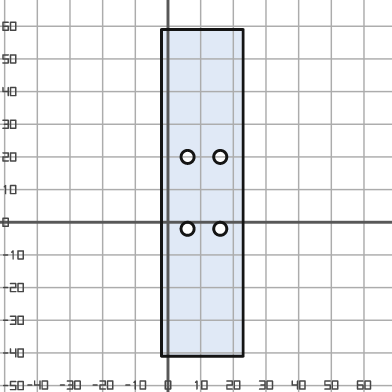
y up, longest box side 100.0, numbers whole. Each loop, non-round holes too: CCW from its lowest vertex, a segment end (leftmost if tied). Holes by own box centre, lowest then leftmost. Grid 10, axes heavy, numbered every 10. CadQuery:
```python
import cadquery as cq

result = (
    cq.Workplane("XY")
    .moveTo(-2.0, -41.0)
    .lineTo(23.0, -41.0)
    .lineTo(23.0, 59.0)
    .lineTo(-2.0, 59.0)
    .close()
    .moveTo(6.0, -2.0)
    .circle(2.0)
    .moveTo(16.0, -2.0)
    .circle(2.0)
    .moveTo(6.0, 20.0)
    .circle(2.0)
    .moveTo(16.0, 20.0)
    .circle(2.0)
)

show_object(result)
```